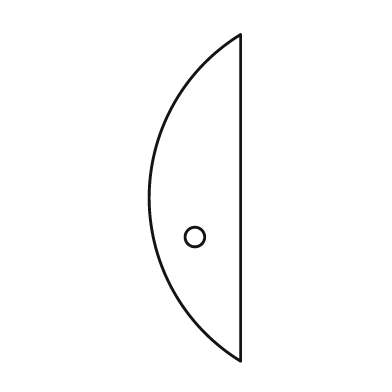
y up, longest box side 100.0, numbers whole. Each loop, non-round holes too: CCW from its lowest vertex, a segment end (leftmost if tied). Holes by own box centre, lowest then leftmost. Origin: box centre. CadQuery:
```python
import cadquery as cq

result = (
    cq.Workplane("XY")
    .moveTo(14.0, -50.0)
    .lineTo(14.0, 50.0)
    .threePointArc((-14.0, 0.0), (14.0, -50.0))
    .close()
    .moveTo(0.0, -12.0)
    .circle(3.0)
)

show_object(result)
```